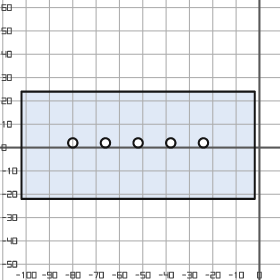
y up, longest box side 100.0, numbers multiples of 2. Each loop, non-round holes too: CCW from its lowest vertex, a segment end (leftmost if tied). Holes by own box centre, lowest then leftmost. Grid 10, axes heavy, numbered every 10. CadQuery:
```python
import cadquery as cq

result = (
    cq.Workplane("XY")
    .moveTo(-102.0, -22.0)
    .lineTo(-2.0, -22.0)
    .lineTo(-2.0, 24.0)
    .lineTo(-102.0, 24.0)
    .close()
    .moveTo(-80.0, 2.0)
    .circle(2.0)
    .moveTo(-66.0, 2.0)
    .circle(2.0)
    .moveTo(-52.0, 2.0)
    .circle(2.0)
    .moveTo(-38.0, 2.0)
    .circle(2.0)
    .moveTo(-24.0, 2.0)
    .circle(2.0)
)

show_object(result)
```